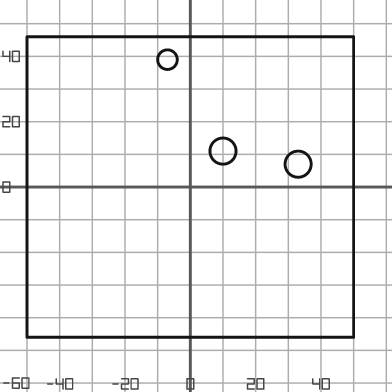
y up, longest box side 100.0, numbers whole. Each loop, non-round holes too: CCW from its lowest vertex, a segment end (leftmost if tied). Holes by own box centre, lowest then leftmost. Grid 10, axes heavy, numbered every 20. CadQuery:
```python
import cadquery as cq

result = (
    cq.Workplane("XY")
    .moveTo(-50.0, -46.0)
    .lineTo(50.0, -46.0)
    .lineTo(50.0, 46.0)
    .lineTo(-50.0, 46.0)
    .close()
    .moveTo(33.0, 7.0)
    .circle(4.0)
    .moveTo(10.0, 11.0)
    .circle(4.0)
    .moveTo(-7.0, 39.0)
    .circle(3.0)
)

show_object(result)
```